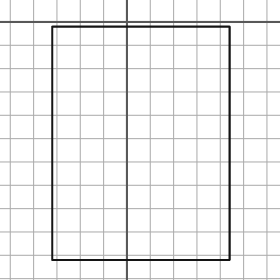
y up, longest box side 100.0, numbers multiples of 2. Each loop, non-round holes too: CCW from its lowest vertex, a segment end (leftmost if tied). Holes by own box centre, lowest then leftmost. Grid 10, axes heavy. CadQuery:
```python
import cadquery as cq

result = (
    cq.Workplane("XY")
    .moveTo(-32.0, -102.0)
    .lineTo(44.0, -102.0)
    .lineTo(44.0, -2.0)
    .lineTo(-32.0, -2.0)
    .close()
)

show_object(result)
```